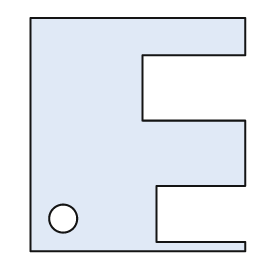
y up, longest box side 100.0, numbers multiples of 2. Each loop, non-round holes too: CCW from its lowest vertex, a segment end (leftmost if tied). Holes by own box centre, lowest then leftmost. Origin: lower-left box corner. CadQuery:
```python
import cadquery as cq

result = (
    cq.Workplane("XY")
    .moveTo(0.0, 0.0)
    .lineTo(92.0, 0.0)
    .lineTo(92.0, 4.0)
    .lineTo(54.0, 4.0)
    .lineTo(54.0, 28.0)
    .lineTo(92.0, 28.0)
    .lineTo(92.0, 56.0)
    .lineTo(48.0, 56.0)
    .lineTo(48.0, 84.0)
    .lineTo(92.0, 84.0)
    .lineTo(92.0, 100.0)
    .lineTo(0.0, 100.0)
    .close()
    .moveTo(14.0, 14.0)
    .circle(6.0)
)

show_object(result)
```